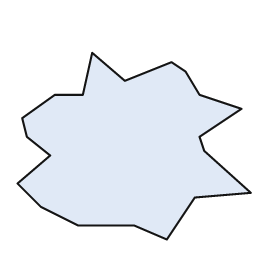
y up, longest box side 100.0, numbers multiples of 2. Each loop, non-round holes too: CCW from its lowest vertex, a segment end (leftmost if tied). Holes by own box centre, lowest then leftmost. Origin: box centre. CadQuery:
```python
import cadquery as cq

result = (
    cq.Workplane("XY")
    .moveTo(14.0, -40.0)
    .lineTo(26.0, -22.0)
    .lineTo(50.0, -20.0)
    .lineTo(30.0, -2.0)
    .lineTo(28.0, 4.0)
    .lineTo(46.0, 16.0)
    .lineTo(28.0, 22.0)
    .lineTo(22.0, 32.0)
    .lineTo(16.0, 36.0)
    .lineTo(-4.0, 28.0)
    .lineTo(-18.0, 40.0)
    .lineTo(-22.0, 22.0)
    .lineTo(-34.0, 22.0)
    .lineTo(-48.0, 12.0)
    .lineTo(-46.0, 4.0)
    .lineTo(-36.0, -4.0)
    .lineTo(-50.0, -16.0)
    .lineTo(-40.0, -26.0)
    .lineTo(-24.0, -34.0)
    .lineTo(0.0, -34.0)
    .close()
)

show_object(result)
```